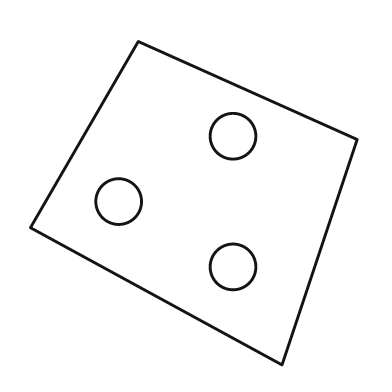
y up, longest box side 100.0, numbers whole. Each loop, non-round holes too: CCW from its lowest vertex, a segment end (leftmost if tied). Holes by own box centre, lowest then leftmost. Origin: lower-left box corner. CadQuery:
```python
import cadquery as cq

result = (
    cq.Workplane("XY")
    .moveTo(77.0, 0.0)
    .lineTo(100.0, 69.0)
    .lineTo(33.0, 99.0)
    .lineTo(0.0, 42.0)
    .close()
    .moveTo(62.0, 30.0)
    .circle(7.0)
    .moveTo(27.0, 50.0)
    .circle(7.0)
    .moveTo(62.0, 70.0)
    .circle(7.0)
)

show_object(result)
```